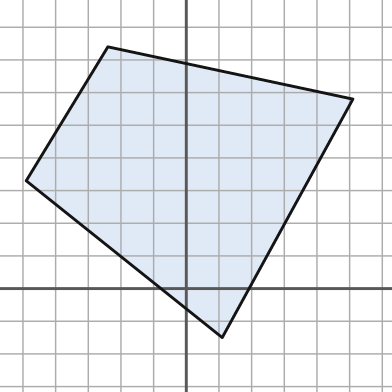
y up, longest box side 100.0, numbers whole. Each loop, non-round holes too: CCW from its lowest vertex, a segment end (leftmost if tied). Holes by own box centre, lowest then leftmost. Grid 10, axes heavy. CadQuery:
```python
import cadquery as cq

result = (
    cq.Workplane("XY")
    .moveTo(11.0, -15.0)
    .lineTo(51.0, 58.0)
    .lineTo(-24.0, 74.0)
    .lineTo(-49.0, 33.0)
    .close()
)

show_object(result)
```